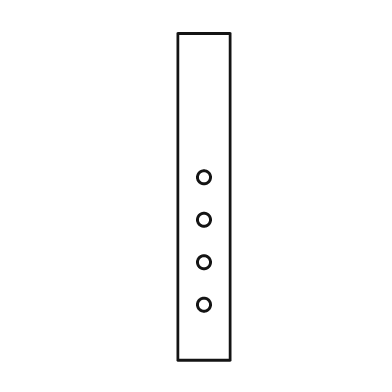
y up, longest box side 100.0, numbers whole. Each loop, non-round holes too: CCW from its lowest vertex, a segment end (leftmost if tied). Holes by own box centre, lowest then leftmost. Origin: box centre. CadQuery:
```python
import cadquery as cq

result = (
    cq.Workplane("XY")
    .moveTo(-8.0, -50.0)
    .lineTo(8.0, -50.0)
    .lineTo(8.0, 50.0)
    .lineTo(-8.0, 50.0)
    .close()
    .moveTo(0.0, -33.0)
    .circle(2.0)
    .moveTo(0.0, -20.0)
    .circle(2.0)
    .moveTo(0.0, -7.0)
    .circle(2.0)
    .moveTo(0.0, 6.0)
    .circle(2.0)
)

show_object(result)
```